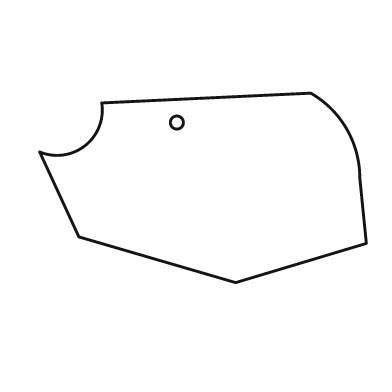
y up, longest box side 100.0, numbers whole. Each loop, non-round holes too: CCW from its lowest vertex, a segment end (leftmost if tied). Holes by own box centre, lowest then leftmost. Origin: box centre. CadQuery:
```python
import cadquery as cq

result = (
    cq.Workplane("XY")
    .moveTo(10.0, -29.0)
    .lineTo(50.0, -17.0)
    .lineTo(48.0, 3.0)
    .threePointArc((44.0, 18.0), (33.0, 29.0))
    .lineTo(-31.0, 26.0)
    .threePointArc((-36.0, 13.0), (-50.0, 11.0))
    .lineTo(-38.0, -15.0)
    .close()
    .moveTo(-8.0, 20.0)
    .circle(2.0)
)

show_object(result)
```